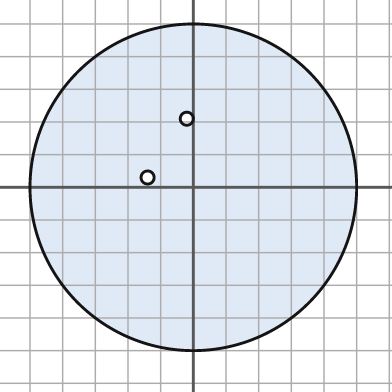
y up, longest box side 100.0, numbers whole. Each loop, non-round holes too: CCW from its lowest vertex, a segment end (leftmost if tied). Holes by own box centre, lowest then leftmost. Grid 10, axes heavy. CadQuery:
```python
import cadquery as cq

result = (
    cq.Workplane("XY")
    .moveTo(0.0, 0.0)
    .circle(50.0)
    .moveTo(-14.0, 3.0)
    .circle(2.0)
    .moveTo(-2.0, 21.0)
    .circle(2.0)
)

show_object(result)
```